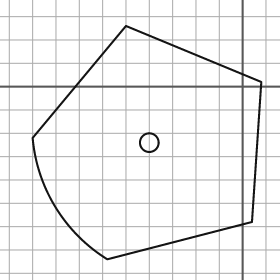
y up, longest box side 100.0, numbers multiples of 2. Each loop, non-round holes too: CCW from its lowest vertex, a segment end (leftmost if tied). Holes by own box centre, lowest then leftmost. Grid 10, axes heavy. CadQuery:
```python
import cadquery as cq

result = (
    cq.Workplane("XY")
    .moveTo(-58.0, -74.0)
    .lineTo(4.0, -58.0)
    .lineTo(8.0, 2.0)
    .lineTo(-50.0, 26.0)
    .lineTo(-90.0, -22.0)
    .threePointArc((-80.0, -52.0), (-58.0, -74.0))
    .close()
    .moveTo(-40.0, -24.0)
    .circle(4.0)
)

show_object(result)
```